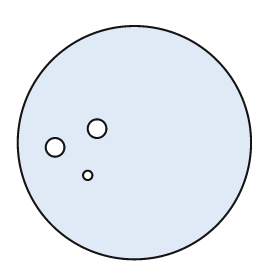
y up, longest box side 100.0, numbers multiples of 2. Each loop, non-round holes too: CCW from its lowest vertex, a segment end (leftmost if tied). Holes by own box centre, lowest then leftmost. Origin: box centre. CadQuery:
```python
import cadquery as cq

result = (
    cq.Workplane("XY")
    .moveTo(0.0, 0.0)
    .circle(50.0)
    .moveTo(-20.0, -14.0)
    .circle(2.0)
    .moveTo(-34.0, -2.0)
    .circle(4.0)
    .moveTo(-16.0, 6.0)
    .circle(4.0)
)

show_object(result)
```